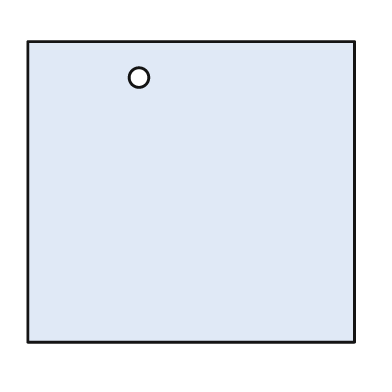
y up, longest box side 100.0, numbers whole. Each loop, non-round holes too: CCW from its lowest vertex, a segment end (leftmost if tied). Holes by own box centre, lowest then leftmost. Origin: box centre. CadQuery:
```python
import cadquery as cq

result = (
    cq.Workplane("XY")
    .moveTo(-50.0, -46.0)
    .lineTo(50.0, -46.0)
    .lineTo(50.0, 46.0)
    .lineTo(-50.0, 46.0)
    .close()
    .moveTo(-16.0, 35.0)
    .circle(3.0)
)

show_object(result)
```